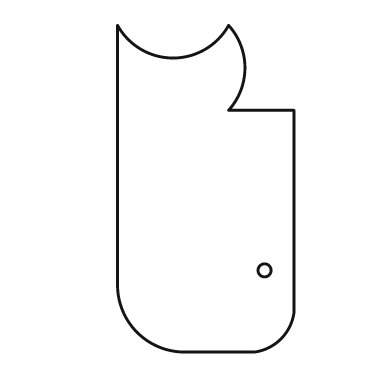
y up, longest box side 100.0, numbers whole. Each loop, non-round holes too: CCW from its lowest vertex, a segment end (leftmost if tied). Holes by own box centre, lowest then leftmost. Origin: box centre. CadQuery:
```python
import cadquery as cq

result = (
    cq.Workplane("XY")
    .moveTo(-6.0, -50.0)
    .lineTo(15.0, -50.0)
    .threePointArc((23.0, -46.0), (27.0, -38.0))
    .lineTo(27.0, 24.0)
    .lineTo(7.0, 24.0)
    .threePointArc((12.0, 37.0), (7.0, 50.0))
    .threePointArc((-10.0, 40.0), (-27.0, 50.0))
    .lineTo(-27.0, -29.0)
    .threePointArc((-21.0, -44.0), (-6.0, -50.0))
    .close()
    .moveTo(18.0, -25.0)
    .circle(2.0)
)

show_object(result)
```